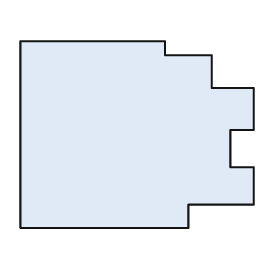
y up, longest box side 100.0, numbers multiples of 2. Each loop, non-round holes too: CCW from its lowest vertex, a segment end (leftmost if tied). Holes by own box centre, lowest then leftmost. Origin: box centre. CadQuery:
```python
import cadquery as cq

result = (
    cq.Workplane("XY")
    .moveTo(-50.0, -40.0)
    .lineTo(22.0, -40.0)
    .lineTo(22.0, -30.0)
    .lineTo(50.0, -30.0)
    .lineTo(50.0, -14.0)
    .lineTo(40.0, -14.0)
    .lineTo(40.0, 2.0)
    .lineTo(50.0, 2.0)
    .lineTo(50.0, 20.0)
    .lineTo(32.0, 20.0)
    .lineTo(32.0, 34.0)
    .lineTo(12.0, 34.0)
    .lineTo(12.0, 40.0)
    .lineTo(-50.0, 40.0)
    .close()
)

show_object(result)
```